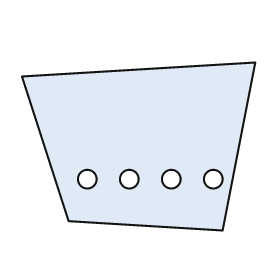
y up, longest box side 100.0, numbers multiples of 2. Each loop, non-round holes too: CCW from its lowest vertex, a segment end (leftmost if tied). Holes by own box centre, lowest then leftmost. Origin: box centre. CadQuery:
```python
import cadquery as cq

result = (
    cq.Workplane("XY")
    .moveTo(36.0, -36.0)
    .lineTo(50.0, 36.0)
    .lineTo(-50.0, 30.0)
    .lineTo(-30.0, -32.0)
    .close()
    .moveTo(-22.0, -14.0)
    .circle(4.0)
    .moveTo(-4.0, -14.0)
    .circle(4.0)
    .moveTo(14.0, -14.0)
    .circle(4.0)
    .moveTo(32.0, -14.0)
    .circle(4.0)
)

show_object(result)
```